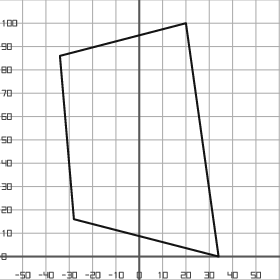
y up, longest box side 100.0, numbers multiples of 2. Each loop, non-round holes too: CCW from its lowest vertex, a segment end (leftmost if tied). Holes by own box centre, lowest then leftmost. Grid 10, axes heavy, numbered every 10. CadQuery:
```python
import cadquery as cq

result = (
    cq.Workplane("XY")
    .moveTo(34.0, 0.0)
    .lineTo(20.0, 100.0)
    .lineTo(-34.0, 86.0)
    .lineTo(-28.0, 16.0)
    .close()
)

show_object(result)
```